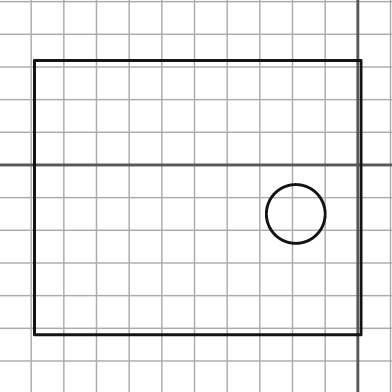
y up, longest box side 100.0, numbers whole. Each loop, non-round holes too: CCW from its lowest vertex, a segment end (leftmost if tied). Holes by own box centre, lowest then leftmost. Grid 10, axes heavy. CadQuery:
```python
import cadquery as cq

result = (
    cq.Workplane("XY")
    .moveTo(-99.0, -52.0)
    .lineTo(1.0, -52.0)
    .lineTo(1.0, 32.0)
    .lineTo(-99.0, 32.0)
    .close()
    .moveTo(-19.0, -15.0)
    .circle(9.0)
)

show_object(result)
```